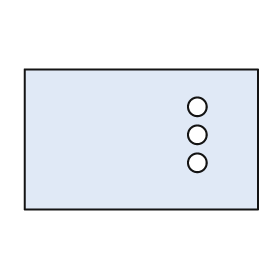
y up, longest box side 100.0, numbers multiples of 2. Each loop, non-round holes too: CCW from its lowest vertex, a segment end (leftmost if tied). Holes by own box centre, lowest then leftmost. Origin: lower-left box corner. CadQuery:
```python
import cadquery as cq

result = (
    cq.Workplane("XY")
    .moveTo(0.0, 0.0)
    .lineTo(100.0, 0.0)
    .lineTo(100.0, 60.0)
    .lineTo(0.0, 60.0)
    .close()
    .moveTo(74.0, 20.0)
    .circle(4.0)
    .moveTo(74.0, 32.0)
    .circle(4.0)
    .moveTo(74.0, 44.0)
    .circle(4.0)
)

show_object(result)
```